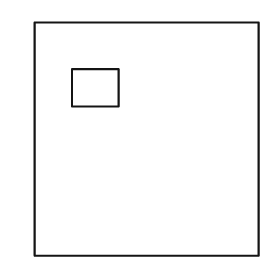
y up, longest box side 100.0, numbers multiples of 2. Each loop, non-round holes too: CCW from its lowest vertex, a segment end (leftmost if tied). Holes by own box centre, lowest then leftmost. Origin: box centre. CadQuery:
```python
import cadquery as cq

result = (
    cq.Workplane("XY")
    .moveTo(-48.0, -50.0)
    .lineTo(48.0, -50.0)
    .lineTo(48.0, 50.0)
    .lineTo(-48.0, 50.0)
    .close()
    .moveTo(-32.0, 14.0)
    .lineTo(-12.0, 14.0)
    .lineTo(-12.0, 30.0)
    .lineTo(-32.0, 30.0)
    .close()
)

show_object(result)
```